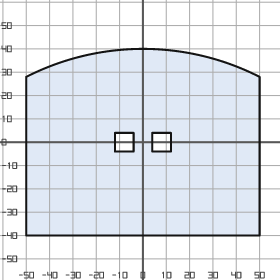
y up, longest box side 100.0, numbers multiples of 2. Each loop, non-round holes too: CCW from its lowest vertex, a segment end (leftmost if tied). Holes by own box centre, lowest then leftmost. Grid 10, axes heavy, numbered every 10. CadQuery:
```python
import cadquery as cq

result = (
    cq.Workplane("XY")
    .moveTo(-50.0, -40.0)
    .lineTo(50.0, -40.0)
    .lineTo(50.0, 28.0)
    .threePointArc((0.0, 40.0), (-50.0, 28.0))
    .close()
    .moveTo(-12.0, -4.0)
    .lineTo(-4.0, -4.0)
    .lineTo(-4.0, 4.0)
    .lineTo(-12.0, 4.0)
    .close()
    .moveTo(4.0, -4.0)
    .lineTo(12.0, -4.0)
    .lineTo(12.0, 4.0)
    .lineTo(4.0, 4.0)
    .close()
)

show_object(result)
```